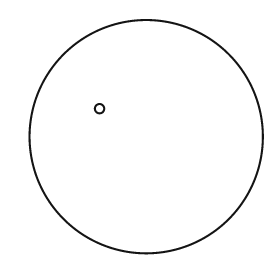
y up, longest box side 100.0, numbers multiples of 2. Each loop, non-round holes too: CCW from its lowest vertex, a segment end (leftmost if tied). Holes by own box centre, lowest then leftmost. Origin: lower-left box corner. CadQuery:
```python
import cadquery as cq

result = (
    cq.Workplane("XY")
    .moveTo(50.0, 50.0)
    .circle(50.0)
    .moveTo(30.0, 62.0)
    .circle(2.0)
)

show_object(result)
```